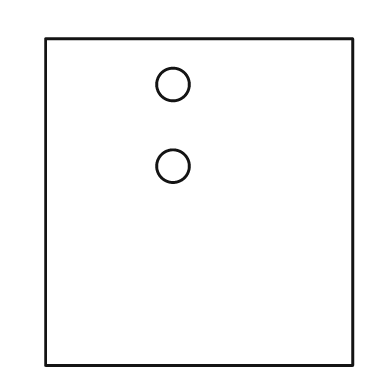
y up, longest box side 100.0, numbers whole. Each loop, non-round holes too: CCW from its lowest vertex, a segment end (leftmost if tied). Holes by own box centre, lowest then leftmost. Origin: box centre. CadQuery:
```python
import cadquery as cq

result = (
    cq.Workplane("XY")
    .moveTo(-47.0, -50.0)
    .lineTo(47.0, -50.0)
    .lineTo(47.0, 50.0)
    .lineTo(-47.0, 50.0)
    .close()
    .moveTo(-8.0, 11.0)
    .circle(5.0)
    .moveTo(-8.0, 36.0)
    .circle(5.0)
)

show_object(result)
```